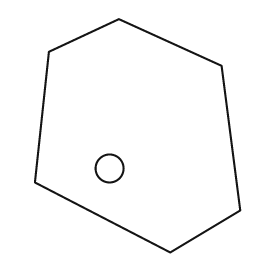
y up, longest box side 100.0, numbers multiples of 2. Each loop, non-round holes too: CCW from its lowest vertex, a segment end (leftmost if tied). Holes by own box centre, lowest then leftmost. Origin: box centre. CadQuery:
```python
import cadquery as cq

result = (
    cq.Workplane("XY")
    .moveTo(14.0, -50.0)
    .lineTo(44.0, -32.0)
    .lineTo(36.0, 30.0)
    .lineTo(-8.0, 50.0)
    .lineTo(-38.0, 36.0)
    .lineTo(-44.0, -20.0)
    .close()
    .moveTo(-12.0, -14.0)
    .circle(6.0)
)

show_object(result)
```